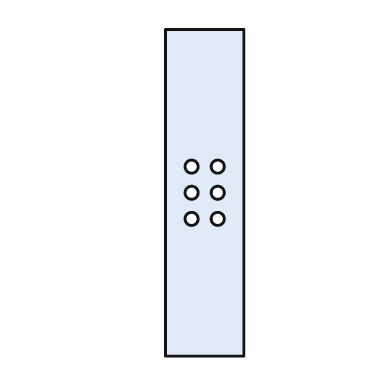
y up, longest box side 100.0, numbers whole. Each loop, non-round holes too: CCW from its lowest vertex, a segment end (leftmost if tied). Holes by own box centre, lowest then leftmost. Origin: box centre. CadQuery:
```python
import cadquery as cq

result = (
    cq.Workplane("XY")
    .moveTo(-12.0, -50.0)
    .lineTo(12.0, -50.0)
    .lineTo(12.0, 50.0)
    .lineTo(-12.0, 50.0)
    .close()
    .moveTo(-4.0, -8.0)
    .circle(2.0)
    .moveTo(4.0, -8.0)
    .circle(2.0)
    .moveTo(-4.0, 0.0)
    .circle(2.0)
    .moveTo(4.0, 0.0)
    .circle(2.0)
    .moveTo(-4.0, 8.0)
    .circle(2.0)
    .moveTo(4.0, 8.0)
    .circle(2.0)
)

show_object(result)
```